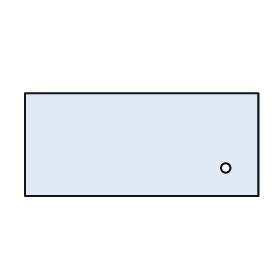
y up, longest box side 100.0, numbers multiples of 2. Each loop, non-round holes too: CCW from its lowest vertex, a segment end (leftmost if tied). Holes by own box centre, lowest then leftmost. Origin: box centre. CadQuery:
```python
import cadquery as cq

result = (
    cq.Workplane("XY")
    .moveTo(-50.0, -22.0)
    .lineTo(50.0, -22.0)
    .lineTo(50.0, 22.0)
    .lineTo(-50.0, 22.0)
    .close()
    .moveTo(36.0, -10.0)
    .circle(2.0)
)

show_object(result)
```